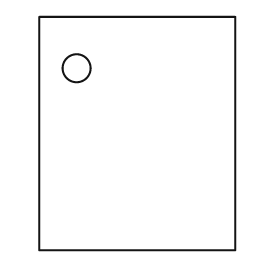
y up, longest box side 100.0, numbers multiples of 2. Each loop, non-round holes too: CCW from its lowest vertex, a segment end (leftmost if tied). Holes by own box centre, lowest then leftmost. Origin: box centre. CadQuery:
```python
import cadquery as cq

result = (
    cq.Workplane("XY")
    .moveTo(-42.0, -50.0)
    .lineTo(42.0, -50.0)
    .lineTo(42.0, 50.0)
    .lineTo(-42.0, 50.0)
    .close()
    .moveTo(-26.0, 28.0)
    .circle(6.0)
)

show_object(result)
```